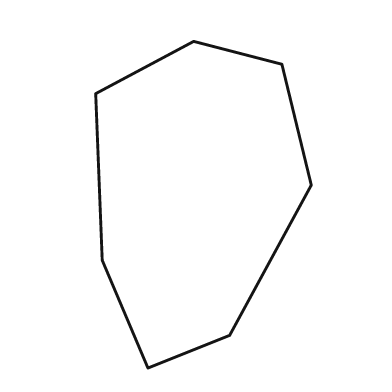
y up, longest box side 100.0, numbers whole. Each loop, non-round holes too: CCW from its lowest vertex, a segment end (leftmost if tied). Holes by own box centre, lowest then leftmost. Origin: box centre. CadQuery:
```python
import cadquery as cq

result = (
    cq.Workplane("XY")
    .moveTo(-17.0, -50.0)
    .lineTo(8.0, -40.0)
    .lineTo(33.0, 6.0)
    .lineTo(24.0, 43.0)
    .lineTo(-3.0, 50.0)
    .lineTo(-33.0, 34.0)
    .lineTo(-31.0, -17.0)
    .close()
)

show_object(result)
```